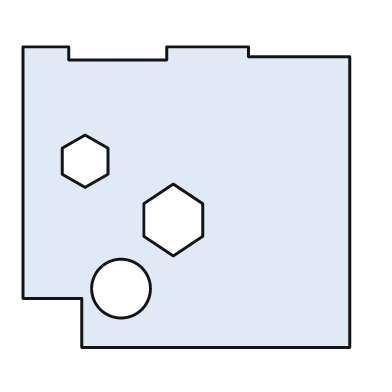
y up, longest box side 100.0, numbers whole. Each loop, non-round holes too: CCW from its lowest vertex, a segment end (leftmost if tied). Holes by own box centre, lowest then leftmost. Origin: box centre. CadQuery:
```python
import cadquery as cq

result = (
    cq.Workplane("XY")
    .moveTo(-32.0, -46.0)
    .lineTo(50.0, -46.0)
    .lineTo(50.0, 43.0)
    .lineTo(19.0, 43.0)
    .lineTo(19.0, 46.0)
    .lineTo(-6.0, 46.0)
    .lineTo(-6.0, 42.0)
    .lineTo(-36.0, 42.0)
    .lineTo(-36.0, 46.0)
    .lineTo(-50.0, 46.0)
    .lineTo(-50.0, -31.0)
    .lineTo(-32.0, -31.0)
    .close()
    .moveTo(-20.0, -28.0)
    .circle(9.0)
    .moveTo(-4.0, -18.0)
    .lineTo(5.0, -12.0)
    .lineTo(5.0, -2.0)
    .lineTo(-4.0, 4.0)
    .lineTo(-13.0, -2.0)
    .lineTo(-13.0, -12.0)
    .close()
    .moveTo(-31.0, 3.0)
    .lineTo(-24.0, 7.0)
    .lineTo(-24.0, 15.0)
    .lineTo(-31.0, 19.0)
    .lineTo(-38.0, 15.0)
    .lineTo(-38.0, 7.0)
    .close()
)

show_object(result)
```